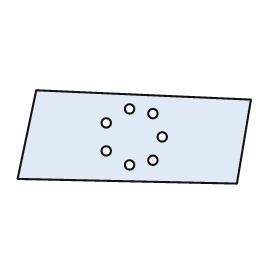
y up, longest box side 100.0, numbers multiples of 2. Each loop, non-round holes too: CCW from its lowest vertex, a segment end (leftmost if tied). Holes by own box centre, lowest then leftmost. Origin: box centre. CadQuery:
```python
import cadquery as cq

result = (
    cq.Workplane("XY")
    .moveTo(44.0, -20.0)
    .lineTo(50.0, 16.0)
    .lineTo(-42.0, 20.0)
    .lineTo(-50.0, -18.0)
    .close()
    .moveTo(-2.0, -12.0)
    .circle(2.0)
    .moveTo(8.0, -10.0)
    .circle(2.0)
    .moveTo(-12.0, -6.0)
    .circle(2.0)
    .moveTo(12.0, 0.0)
    .circle(2.0)
    .moveTo(-12.0, 6.0)
    .circle(2.0)
    .moveTo(8.0, 10.0)
    .circle(2.0)
    .moveTo(-2.0, 12.0)
    .circle(2.0)
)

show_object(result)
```